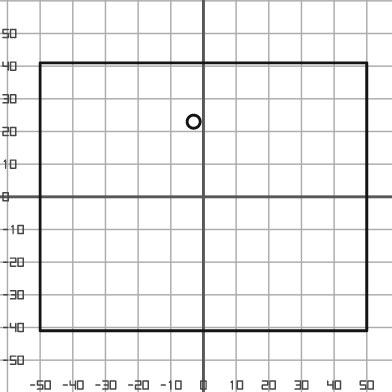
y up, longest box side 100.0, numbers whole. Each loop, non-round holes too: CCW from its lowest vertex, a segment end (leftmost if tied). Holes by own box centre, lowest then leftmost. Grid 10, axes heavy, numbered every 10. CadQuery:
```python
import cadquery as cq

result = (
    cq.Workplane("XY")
    .moveTo(-50.0, -41.0)
    .lineTo(50.0, -41.0)
    .lineTo(50.0, 41.0)
    .lineTo(-50.0, 41.0)
    .close()
    .moveTo(-3.0, 23.0)
    .circle(2.0)
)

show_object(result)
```